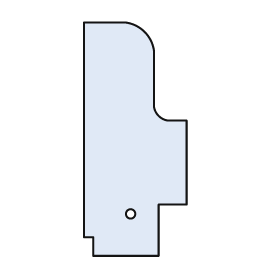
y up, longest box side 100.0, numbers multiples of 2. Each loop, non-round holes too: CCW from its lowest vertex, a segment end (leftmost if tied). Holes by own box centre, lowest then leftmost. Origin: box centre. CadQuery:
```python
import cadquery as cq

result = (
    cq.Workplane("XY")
    .moveTo(-18.0, -50.0)
    .lineTo(10.0, -50.0)
    .lineTo(10.0, -28.0)
    .lineTo(22.0, -28.0)
    .lineTo(22.0, 8.0)
    .lineTo(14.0, 8.0)
    .threePointArc((10.0, 10.0), (8.0, 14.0))
    .lineTo(8.0, 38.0)
    .threePointArc((4.0, 46.0), (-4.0, 50.0))
    .lineTo(-22.0, 50.0)
    .lineTo(-22.0, -42.0)
    .lineTo(-18.0, -42.0)
    .close()
    .moveTo(-2.0, -32.0)
    .circle(2.0)
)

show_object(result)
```